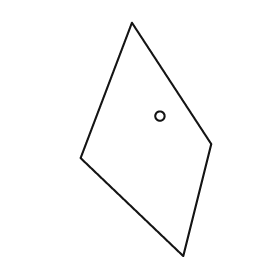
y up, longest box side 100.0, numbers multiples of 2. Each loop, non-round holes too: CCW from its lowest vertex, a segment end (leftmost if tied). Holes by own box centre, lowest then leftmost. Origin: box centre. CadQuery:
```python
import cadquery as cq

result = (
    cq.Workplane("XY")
    .moveTo(16.0, -50.0)
    .lineTo(28.0, -2.0)
    .lineTo(-6.0, 50.0)
    .lineTo(-28.0, -8.0)
    .close()
    .moveTo(6.0, 10.0)
    .circle(2.0)
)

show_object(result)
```